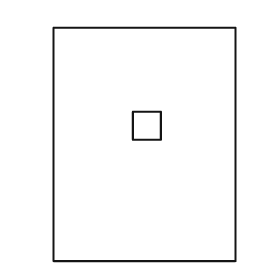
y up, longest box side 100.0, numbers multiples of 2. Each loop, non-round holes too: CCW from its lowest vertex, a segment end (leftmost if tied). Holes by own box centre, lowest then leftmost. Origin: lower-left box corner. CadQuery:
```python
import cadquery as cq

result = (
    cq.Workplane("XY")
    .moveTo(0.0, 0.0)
    .lineTo(78.0, 0.0)
    .lineTo(78.0, 100.0)
    .lineTo(0.0, 100.0)
    .close()
    .moveTo(34.0, 52.0)
    .lineTo(46.0, 52.0)
    .lineTo(46.0, 64.0)
    .lineTo(34.0, 64.0)
    .close()
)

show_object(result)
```